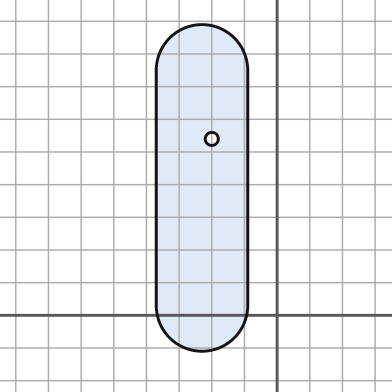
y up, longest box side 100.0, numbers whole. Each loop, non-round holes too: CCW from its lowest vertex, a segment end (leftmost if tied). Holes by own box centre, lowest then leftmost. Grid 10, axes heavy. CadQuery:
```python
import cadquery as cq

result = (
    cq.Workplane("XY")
    .moveTo(-37.0, 3.0)
    .threePointArc((-23.0, -11.0), (-9.0, 3.0))
    .lineTo(-9.0, 75.0)
    .threePointArc((-23.0, 89.0), (-37.0, 75.0))
    .close()
    .moveTo(-20.0, 54.0)
    .circle(2.0)
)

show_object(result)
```